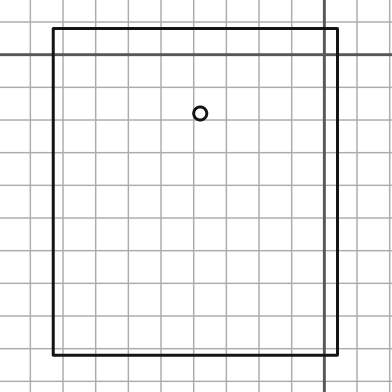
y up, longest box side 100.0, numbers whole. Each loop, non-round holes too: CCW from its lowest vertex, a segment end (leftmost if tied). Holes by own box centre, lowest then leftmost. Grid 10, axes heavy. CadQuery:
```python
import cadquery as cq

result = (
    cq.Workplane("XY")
    .moveTo(-83.0, -92.0)
    .lineTo(4.0, -92.0)
    .lineTo(4.0, 8.0)
    .lineTo(-83.0, 8.0)
    .close()
    .moveTo(-38.0, -18.0)
    .circle(2.0)
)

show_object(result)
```